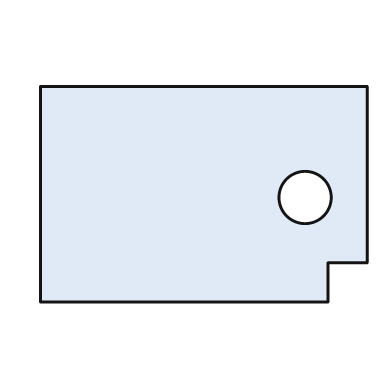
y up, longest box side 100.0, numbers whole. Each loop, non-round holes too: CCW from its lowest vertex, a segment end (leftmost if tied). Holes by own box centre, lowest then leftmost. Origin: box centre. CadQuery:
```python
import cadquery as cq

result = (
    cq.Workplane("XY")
    .moveTo(-50.0, -33.0)
    .lineTo(38.0, -33.0)
    .lineTo(38.0, -21.0)
    .lineTo(50.0, -21.0)
    .lineTo(50.0, 33.0)
    .lineTo(-50.0, 33.0)
    .close()
    .moveTo(31.0, -1.0)
    .circle(8.0)
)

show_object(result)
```